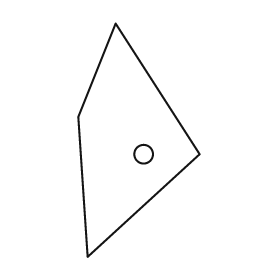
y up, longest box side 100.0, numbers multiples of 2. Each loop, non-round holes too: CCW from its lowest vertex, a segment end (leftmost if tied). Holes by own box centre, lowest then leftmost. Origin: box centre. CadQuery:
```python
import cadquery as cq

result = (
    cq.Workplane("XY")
    .moveTo(-22.0, -50.0)
    .lineTo(26.0, -6.0)
    .lineTo(-10.0, 50.0)
    .lineTo(-26.0, 10.0)
    .close()
    .moveTo(2.0, -6.0)
    .circle(4.0)
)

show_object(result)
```